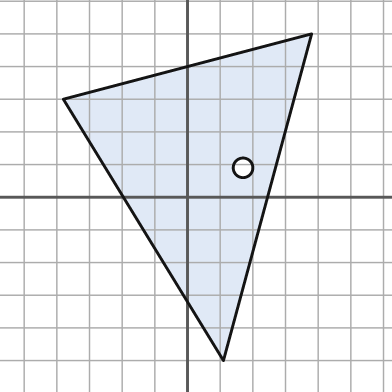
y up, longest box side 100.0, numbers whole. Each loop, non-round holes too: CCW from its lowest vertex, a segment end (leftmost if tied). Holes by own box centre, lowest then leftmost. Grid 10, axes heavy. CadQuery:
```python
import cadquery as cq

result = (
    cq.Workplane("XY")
    .moveTo(11.0, -50.0)
    .lineTo(38.0, 50.0)
    .lineTo(-38.0, 30.0)
    .close()
    .moveTo(17.0, 9.0)
    .circle(3.0)
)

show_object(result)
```